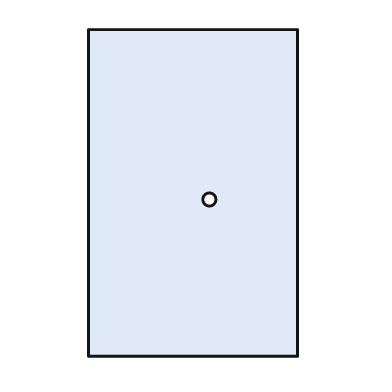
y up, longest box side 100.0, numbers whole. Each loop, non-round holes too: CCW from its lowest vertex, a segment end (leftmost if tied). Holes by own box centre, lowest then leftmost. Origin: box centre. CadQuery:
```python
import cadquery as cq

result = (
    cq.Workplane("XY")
    .moveTo(-32.0, -50.0)
    .lineTo(32.0, -50.0)
    .lineTo(32.0, 50.0)
    .lineTo(-32.0, 50.0)
    .close()
    .moveTo(5.0, -2.0)
    .circle(2.0)
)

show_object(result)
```